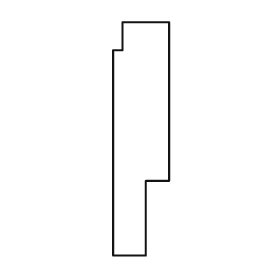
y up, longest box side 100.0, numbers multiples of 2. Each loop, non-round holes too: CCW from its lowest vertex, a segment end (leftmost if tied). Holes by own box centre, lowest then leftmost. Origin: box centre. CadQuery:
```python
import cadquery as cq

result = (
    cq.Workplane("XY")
    .moveTo(-12.0, -50.0)
    .lineTo(2.0, -50.0)
    .lineTo(2.0, -18.0)
    .lineTo(12.0, -18.0)
    .lineTo(12.0, 50.0)
    .lineTo(-8.0, 50.0)
    .lineTo(-8.0, 38.0)
    .lineTo(-12.0, 38.0)
    .close()
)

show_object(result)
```